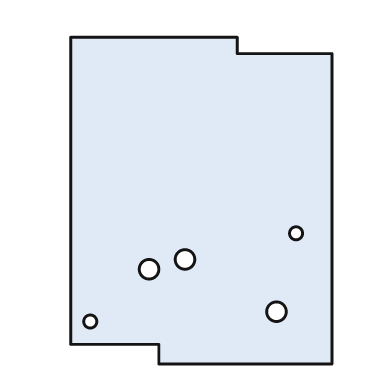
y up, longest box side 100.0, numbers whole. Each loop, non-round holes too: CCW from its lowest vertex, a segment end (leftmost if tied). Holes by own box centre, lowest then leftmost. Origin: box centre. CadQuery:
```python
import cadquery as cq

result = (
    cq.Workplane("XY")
    .moveTo(-13.0, -50.0)
    .lineTo(40.0, -50.0)
    .lineTo(40.0, 45.0)
    .lineTo(11.0, 45.0)
    .lineTo(11.0, 50.0)
    .lineTo(-40.0, 50.0)
    .lineTo(-40.0, -44.0)
    .lineTo(-13.0, -44.0)
    .close()
    .moveTo(-34.0, -37.0)
    .circle(2.0)
    .moveTo(23.0, -34.0)
    .circle(3.0)
    .moveTo(-16.0, -21.0)
    .circle(3.0)
    .moveTo(-5.0, -18.0)
    .circle(3.0)
    .moveTo(29.0, -10.0)
    .circle(2.0)
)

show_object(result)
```